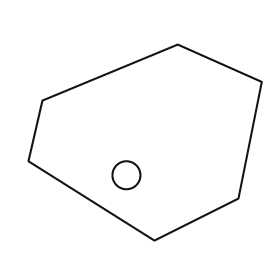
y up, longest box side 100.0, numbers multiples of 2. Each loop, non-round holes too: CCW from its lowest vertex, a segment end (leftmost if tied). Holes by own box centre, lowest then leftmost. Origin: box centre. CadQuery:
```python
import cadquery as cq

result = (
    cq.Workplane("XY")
    .moveTo(4.0, -42.0)
    .lineTo(40.0, -24.0)
    .lineTo(50.0, 26.0)
    .lineTo(14.0, 42.0)
    .lineTo(-44.0, 18.0)
    .lineTo(-50.0, -8.0)
    .close()
    .moveTo(-8.0, -14.0)
    .circle(6.0)
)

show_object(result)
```